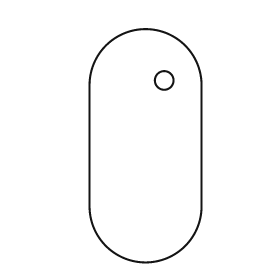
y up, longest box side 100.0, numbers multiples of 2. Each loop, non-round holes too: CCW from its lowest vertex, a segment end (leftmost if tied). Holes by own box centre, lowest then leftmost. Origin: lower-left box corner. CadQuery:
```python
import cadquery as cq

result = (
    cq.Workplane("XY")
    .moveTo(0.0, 24.0)
    .threePointArc((24.0, 0.0), (48.0, 24.0))
    .lineTo(48.0, 76.0)
    .threePointArc((24.0, 100.0), (0.0, 76.0))
    .close()
    .moveTo(32.0, 78.0)
    .circle(4.0)
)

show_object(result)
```